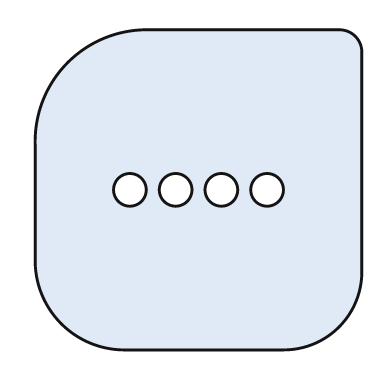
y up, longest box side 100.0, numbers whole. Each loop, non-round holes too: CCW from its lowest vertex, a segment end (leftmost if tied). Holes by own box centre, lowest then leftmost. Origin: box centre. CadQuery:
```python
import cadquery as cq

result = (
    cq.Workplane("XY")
    .moveTo(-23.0, -49.0)
    .lineTo(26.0, -49.0)
    .threePointArc((43.0, -42.0), (50.0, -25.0))
    .lineTo(50.0, 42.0)
    .threePointArc((48.0, 47.0), (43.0, 49.0))
    .lineTo(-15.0, 49.0)
    .threePointArc((-40.0, 39.0), (-50.0, 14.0))
    .lineTo(-50.0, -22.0)
    .threePointArc((-42.0, -41.0), (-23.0, -49.0))
    .close()
    .moveTo(-21.0, 0.0)
    .circle(5.0)
    .moveTo(-7.0, 0.0)
    .circle(5.0)
    .moveTo(7.0, 0.0)
    .circle(5.0)
    .moveTo(21.0, 0.0)
    .circle(5.0)
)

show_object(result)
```